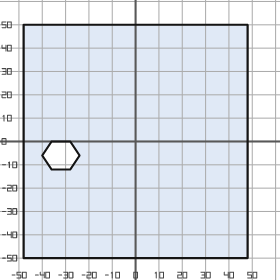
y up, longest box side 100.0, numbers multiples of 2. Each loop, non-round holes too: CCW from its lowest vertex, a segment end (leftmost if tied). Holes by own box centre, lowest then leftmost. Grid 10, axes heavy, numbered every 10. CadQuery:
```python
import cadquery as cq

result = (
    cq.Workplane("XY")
    .moveTo(-48.0, -50.0)
    .lineTo(48.0, -50.0)
    .lineTo(48.0, 50.0)
    .lineTo(-48.0, 50.0)
    .close()
    .moveTo(-36.0, -12.0)
    .lineTo(-28.0, -12.0)
    .lineTo(-24.0, -6.0)
    .lineTo(-28.0, 0.0)
    .lineTo(-36.0, 0.0)
    .lineTo(-40.0, -6.0)
    .close()
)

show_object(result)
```